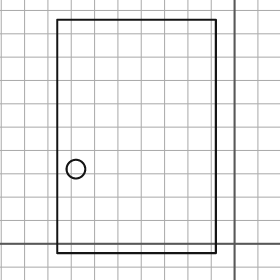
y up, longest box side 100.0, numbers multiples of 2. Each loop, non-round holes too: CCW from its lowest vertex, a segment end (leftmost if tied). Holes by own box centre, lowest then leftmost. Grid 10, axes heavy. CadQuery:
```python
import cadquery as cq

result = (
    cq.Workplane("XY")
    .moveTo(-76.0, -4.0)
    .lineTo(-8.0, -4.0)
    .lineTo(-8.0, 96.0)
    .lineTo(-76.0, 96.0)
    .close()
    .moveTo(-68.0, 32.0)
    .circle(4.0)
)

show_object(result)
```